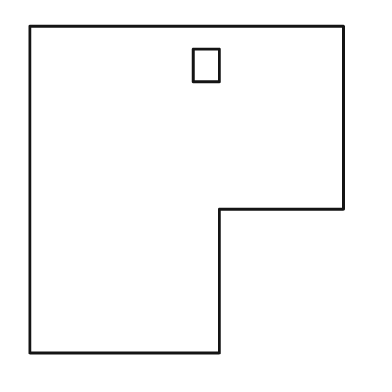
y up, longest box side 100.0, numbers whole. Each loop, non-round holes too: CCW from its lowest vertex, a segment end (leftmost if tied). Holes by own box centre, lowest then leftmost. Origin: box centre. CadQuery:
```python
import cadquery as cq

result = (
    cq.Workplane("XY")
    .moveTo(-48.0, -50.0)
    .lineTo(10.0, -50.0)
    .lineTo(10.0, -6.0)
    .lineTo(48.0, -6.0)
    .lineTo(48.0, 50.0)
    .lineTo(-48.0, 50.0)
    .close()
    .moveTo(2.0, 33.0)
    .lineTo(10.0, 33.0)
    .lineTo(10.0, 43.0)
    .lineTo(2.0, 43.0)
    .close()
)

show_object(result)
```